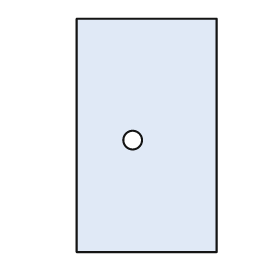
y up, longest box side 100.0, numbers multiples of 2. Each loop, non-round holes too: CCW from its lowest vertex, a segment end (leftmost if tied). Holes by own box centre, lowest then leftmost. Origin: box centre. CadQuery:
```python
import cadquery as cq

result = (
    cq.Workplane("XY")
    .moveTo(-30.0, -50.0)
    .lineTo(30.0, -50.0)
    .lineTo(30.0, 50.0)
    .lineTo(-30.0, 50.0)
    .close()
    .moveTo(-6.0, -2.0)
    .circle(4.0)
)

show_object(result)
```